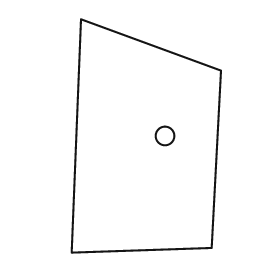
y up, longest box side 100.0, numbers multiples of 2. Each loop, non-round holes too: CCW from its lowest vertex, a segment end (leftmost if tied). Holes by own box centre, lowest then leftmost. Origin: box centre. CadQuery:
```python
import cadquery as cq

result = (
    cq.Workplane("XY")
    .moveTo(-32.0, -50.0)
    .lineTo(28.0, -48.0)
    .lineTo(32.0, 28.0)
    .lineTo(-28.0, 50.0)
    .close()
    .moveTo(8.0, 0.0)
    .circle(4.0)
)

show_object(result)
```